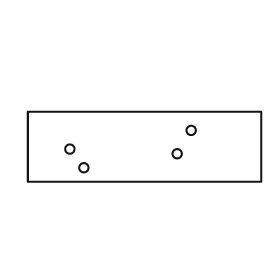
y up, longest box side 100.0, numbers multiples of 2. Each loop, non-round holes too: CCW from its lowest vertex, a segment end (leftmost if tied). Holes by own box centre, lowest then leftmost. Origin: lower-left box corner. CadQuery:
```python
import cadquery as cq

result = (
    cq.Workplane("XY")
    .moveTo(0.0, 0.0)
    .lineTo(100.0, 0.0)
    .lineTo(100.0, 30.0)
    .lineTo(0.0, 30.0)
    .close()
    .moveTo(24.0, 6.0)
    .circle(2.0)
    .moveTo(64.0, 12.0)
    .circle(2.0)
    .moveTo(18.0, 14.0)
    .circle(2.0)
    .moveTo(70.0, 22.0)
    .circle(2.0)
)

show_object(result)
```